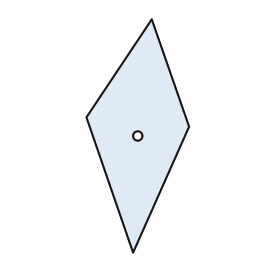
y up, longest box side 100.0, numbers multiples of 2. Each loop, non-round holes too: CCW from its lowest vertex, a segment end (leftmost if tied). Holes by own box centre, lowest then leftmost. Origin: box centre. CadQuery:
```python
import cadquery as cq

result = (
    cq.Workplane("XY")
    .moveTo(-2.0, -50.0)
    .lineTo(22.0, 4.0)
    .lineTo(6.0, 50.0)
    .lineTo(-22.0, 8.0)
    .close()
    .moveTo(0.0, 0.0)
    .circle(2.0)
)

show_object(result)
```